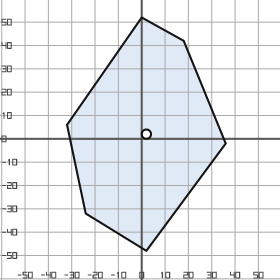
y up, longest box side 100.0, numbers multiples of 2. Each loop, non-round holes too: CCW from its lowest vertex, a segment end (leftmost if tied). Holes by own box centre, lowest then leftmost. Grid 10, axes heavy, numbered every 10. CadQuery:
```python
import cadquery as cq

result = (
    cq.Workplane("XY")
    .moveTo(2.0, -48.0)
    .lineTo(36.0, -2.0)
    .lineTo(18.0, 42.0)
    .lineTo(0.0, 52.0)
    .lineTo(-32.0, 6.0)
    .lineTo(-24.0, -32.0)
    .close()
    .moveTo(2.0, 2.0)
    .circle(2.0)
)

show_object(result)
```